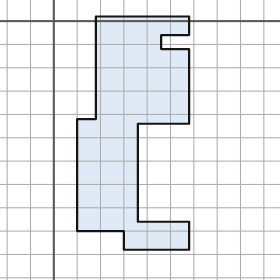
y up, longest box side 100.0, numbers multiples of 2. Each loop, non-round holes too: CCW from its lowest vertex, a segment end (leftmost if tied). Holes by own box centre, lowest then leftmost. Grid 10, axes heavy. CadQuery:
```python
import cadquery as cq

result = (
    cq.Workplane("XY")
    .moveTo(30.0, -98.0)
    .lineTo(58.0, -98.0)
    .lineTo(58.0, -86.0)
    .lineTo(36.0, -86.0)
    .lineTo(36.0, -44.0)
    .lineTo(58.0, -44.0)
    .lineTo(58.0, -12.0)
    .lineTo(46.0, -12.0)
    .lineTo(46.0, -6.0)
    .lineTo(58.0, -6.0)
    .lineTo(58.0, 2.0)
    .lineTo(18.0, 2.0)
    .lineTo(18.0, -42.0)
    .lineTo(10.0, -42.0)
    .lineTo(10.0, -90.0)
    .lineTo(30.0, -90.0)
    .close()
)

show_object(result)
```